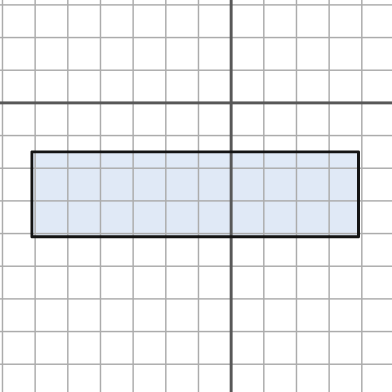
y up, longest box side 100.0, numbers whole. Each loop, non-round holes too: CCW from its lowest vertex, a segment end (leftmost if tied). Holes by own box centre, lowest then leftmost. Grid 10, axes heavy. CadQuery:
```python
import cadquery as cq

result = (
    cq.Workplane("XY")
    .moveTo(-61.0, -41.0)
    .lineTo(39.0, -41.0)
    .lineTo(39.0, -15.0)
    .lineTo(-61.0, -15.0)
    .close()
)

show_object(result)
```